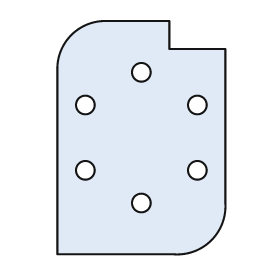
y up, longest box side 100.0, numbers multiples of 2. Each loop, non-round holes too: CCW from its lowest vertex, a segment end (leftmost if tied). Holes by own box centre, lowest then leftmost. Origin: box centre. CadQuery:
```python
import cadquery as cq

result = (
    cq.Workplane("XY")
    .moveTo(-36.0, -50.0)
    .lineTo(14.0, -50.0)
    .threePointArc((30.0, -44.0), (36.0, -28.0))
    .lineTo(36.0, 38.0)
    .lineTo(12.0, 38.0)
    .lineTo(12.0, 50.0)
    .lineTo(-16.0, 50.0)
    .threePointArc((-30.0, 44.0), (-36.0, 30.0))
    .close()
    .moveTo(0.0, -28.0)
    .circle(4.0)
    .moveTo(-24.0, -14.0)
    .circle(4.0)
    .moveTo(24.0, -14.0)
    .circle(4.0)
    .moveTo(-24.0, 14.0)
    .circle(4.0)
    .moveTo(24.0, 14.0)
    .circle(4.0)
    .moveTo(0.0, 28.0)
    .circle(4.0)
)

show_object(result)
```